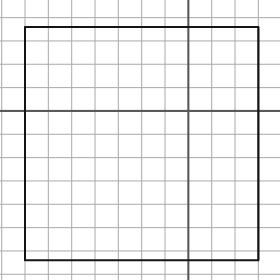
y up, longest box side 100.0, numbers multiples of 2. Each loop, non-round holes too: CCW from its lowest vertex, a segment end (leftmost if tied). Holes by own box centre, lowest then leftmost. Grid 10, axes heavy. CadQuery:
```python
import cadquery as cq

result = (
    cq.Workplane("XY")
    .moveTo(-70.0, -64.0)
    .lineTo(30.0, -64.0)
    .lineTo(30.0, 36.0)
    .lineTo(-70.0, 36.0)
    .close()
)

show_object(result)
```